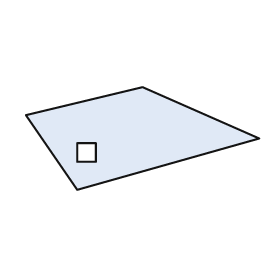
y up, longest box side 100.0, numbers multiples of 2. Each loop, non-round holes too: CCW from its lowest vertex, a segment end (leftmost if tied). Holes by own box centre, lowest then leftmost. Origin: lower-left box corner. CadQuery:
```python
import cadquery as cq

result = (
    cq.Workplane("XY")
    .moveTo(22.0, 0.0)
    .lineTo(100.0, 22.0)
    .lineTo(50.0, 44.0)
    .lineTo(0.0, 32.0)
    .close()
    .moveTo(22.0, 12.0)
    .lineTo(30.0, 12.0)
    .lineTo(30.0, 20.0)
    .lineTo(22.0, 20.0)
    .close()
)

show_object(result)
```